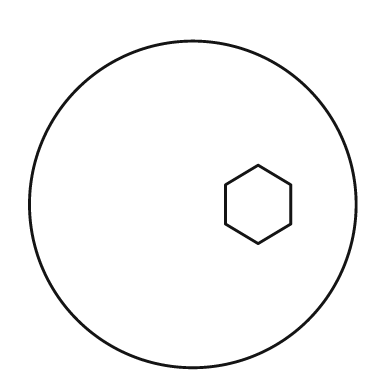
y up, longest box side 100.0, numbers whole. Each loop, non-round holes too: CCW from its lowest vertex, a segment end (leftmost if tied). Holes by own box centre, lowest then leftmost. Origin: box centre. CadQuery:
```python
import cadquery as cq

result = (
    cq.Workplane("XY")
    .moveTo(0.0, 0.0)
    .circle(50.0)
    .moveTo(20.0, -12.0)
    .lineTo(30.0, -6.0)
    .lineTo(30.0, 6.0)
    .lineTo(20.0, 12.0)
    .lineTo(10.0, 6.0)
    .lineTo(10.0, -6.0)
    .close()
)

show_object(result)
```